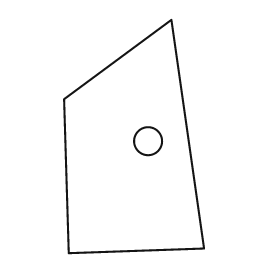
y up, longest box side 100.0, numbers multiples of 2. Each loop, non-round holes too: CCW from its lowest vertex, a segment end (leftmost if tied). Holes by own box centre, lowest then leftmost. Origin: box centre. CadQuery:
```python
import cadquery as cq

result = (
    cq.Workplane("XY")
    .moveTo(-28.0, -50.0)
    .lineTo(30.0, -48.0)
    .lineTo(16.0, 50.0)
    .lineTo(-30.0, 16.0)
    .close()
    .moveTo(6.0, -2.0)
    .circle(6.0)
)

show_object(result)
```